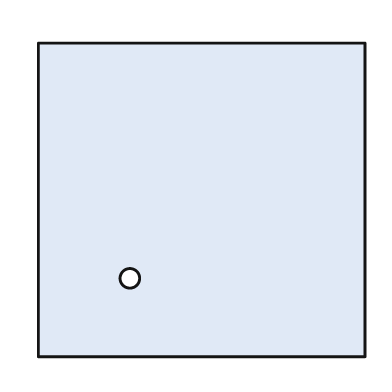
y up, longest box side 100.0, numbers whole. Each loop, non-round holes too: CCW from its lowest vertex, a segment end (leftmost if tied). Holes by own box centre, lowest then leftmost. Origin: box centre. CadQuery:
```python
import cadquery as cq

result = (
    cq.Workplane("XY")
    .moveTo(-50.0, -48.0)
    .lineTo(50.0, -48.0)
    .lineTo(50.0, 48.0)
    .lineTo(-50.0, 48.0)
    .close()
    .moveTo(-22.0, -24.0)
    .circle(3.0)
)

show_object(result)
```